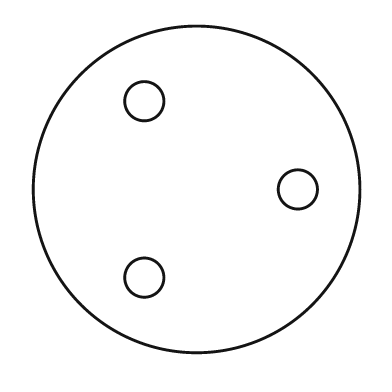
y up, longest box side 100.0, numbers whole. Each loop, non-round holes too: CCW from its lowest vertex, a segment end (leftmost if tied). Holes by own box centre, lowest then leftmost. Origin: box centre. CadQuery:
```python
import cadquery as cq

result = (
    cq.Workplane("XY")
    .moveTo(0.0, 0.0)
    .circle(50.0)
    .moveTo(-16.0, -27.0)
    .circle(6.0)
    .moveTo(31.0, 0.0)
    .circle(6.0)
    .moveTo(-16.0, 27.0)
    .circle(6.0)
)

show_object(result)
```